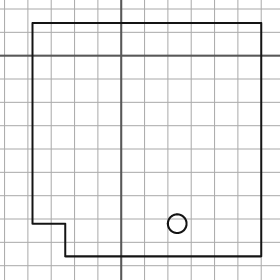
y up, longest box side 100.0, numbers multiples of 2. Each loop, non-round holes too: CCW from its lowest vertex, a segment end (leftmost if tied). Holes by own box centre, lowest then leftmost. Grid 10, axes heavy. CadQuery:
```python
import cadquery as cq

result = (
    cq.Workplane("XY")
    .moveTo(-24.0, -86.0)
    .lineTo(60.0, -86.0)
    .lineTo(60.0, 14.0)
    .lineTo(-38.0, 14.0)
    .lineTo(-38.0, -72.0)
    .lineTo(-24.0, -72.0)
    .close()
    .moveTo(24.0, -72.0)
    .circle(4.0)
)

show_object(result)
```